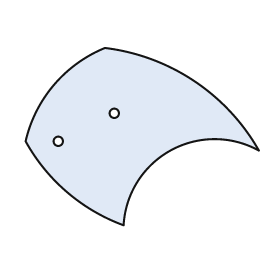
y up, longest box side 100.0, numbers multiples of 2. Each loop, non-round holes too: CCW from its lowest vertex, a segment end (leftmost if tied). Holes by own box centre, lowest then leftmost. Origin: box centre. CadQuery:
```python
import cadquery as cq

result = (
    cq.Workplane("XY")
    .moveTo(-8.0, -38.0)
    .threePointArc((12.0, -6.0), (50.0, -6.0))
    .threePointArc((22.0, 24.0), (-16.0, 38.0))
    .threePointArc((-38.0, 22.0), (-50.0, -2.0))
    .threePointArc((-32.0, -24.0), (-8.0, -38.0))
    .close()
    .moveTo(-36.0, -2.0)
    .circle(2.0)
    .moveTo(-12.0, 10.0)
    .circle(2.0)
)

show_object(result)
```